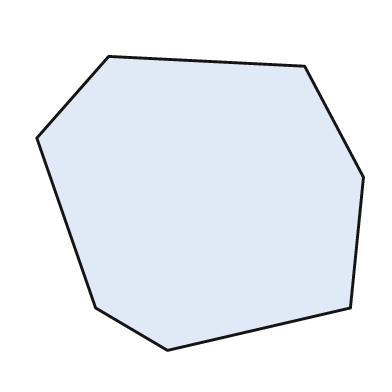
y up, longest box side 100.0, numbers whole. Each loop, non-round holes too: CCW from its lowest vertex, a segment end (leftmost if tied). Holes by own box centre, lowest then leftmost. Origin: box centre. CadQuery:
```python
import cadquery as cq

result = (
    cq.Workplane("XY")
    .moveTo(-10.0, -45.0)
    .lineTo(46.0, -32.0)
    .lineTo(50.0, 8.0)
    .lineTo(32.0, 42.0)
    .lineTo(-28.0, 45.0)
    .lineTo(-50.0, 20.0)
    .lineTo(-32.0, -32.0)
    .close()
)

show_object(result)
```